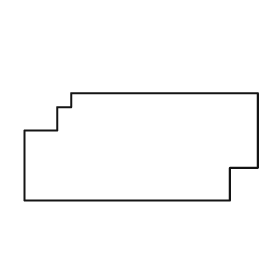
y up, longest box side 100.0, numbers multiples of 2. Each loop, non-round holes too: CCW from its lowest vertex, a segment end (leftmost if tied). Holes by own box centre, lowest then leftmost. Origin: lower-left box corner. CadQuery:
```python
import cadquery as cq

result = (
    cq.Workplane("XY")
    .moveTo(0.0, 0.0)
    .lineTo(88.0, 0.0)
    .lineTo(88.0, 14.0)
    .lineTo(100.0, 14.0)
    .lineTo(100.0, 46.0)
    .lineTo(20.0, 46.0)
    .lineTo(20.0, 40.0)
    .lineTo(14.0, 40.0)
    .lineTo(14.0, 30.0)
    .lineTo(0.0, 30.0)
    .close()
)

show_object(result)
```